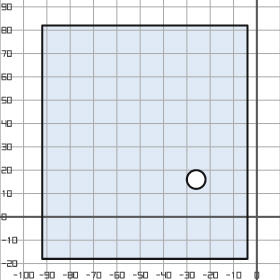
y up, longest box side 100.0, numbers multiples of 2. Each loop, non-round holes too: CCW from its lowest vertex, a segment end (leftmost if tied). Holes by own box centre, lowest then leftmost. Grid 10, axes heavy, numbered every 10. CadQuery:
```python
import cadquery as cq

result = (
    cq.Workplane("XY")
    .moveTo(-92.0, -18.0)
    .lineTo(-4.0, -18.0)
    .lineTo(-4.0, 82.0)
    .lineTo(-92.0, 82.0)
    .close()
    .moveTo(-26.0, 16.0)
    .circle(4.0)
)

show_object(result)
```